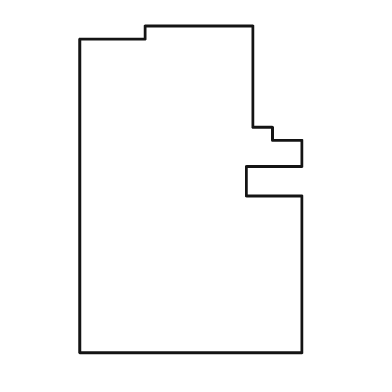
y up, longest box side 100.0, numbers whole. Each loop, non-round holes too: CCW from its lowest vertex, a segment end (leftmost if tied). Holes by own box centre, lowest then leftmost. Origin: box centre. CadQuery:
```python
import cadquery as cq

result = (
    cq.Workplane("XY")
    .moveTo(-34.0, -50.0)
    .lineTo(34.0, -50.0)
    .lineTo(34.0, -2.0)
    .lineTo(17.0, -2.0)
    .lineTo(17.0, 7.0)
    .lineTo(34.0, 7.0)
    .lineTo(34.0, 15.0)
    .lineTo(25.0, 15.0)
    .lineTo(25.0, 19.0)
    .lineTo(19.0, 19.0)
    .lineTo(19.0, 50.0)
    .lineTo(-14.0, 50.0)
    .lineTo(-14.0, 46.0)
    .lineTo(-34.0, 46.0)
    .close()
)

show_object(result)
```